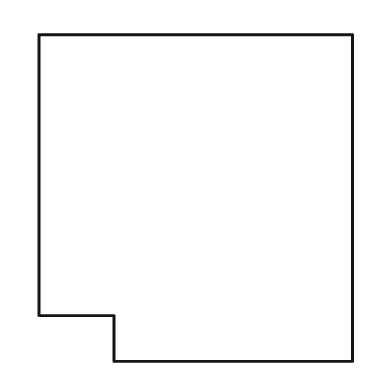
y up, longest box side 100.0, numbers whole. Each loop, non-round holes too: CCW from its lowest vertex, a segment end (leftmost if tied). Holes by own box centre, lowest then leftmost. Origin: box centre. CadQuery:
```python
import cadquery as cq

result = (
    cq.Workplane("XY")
    .moveTo(-25.0, -50.0)
    .lineTo(48.0, -50.0)
    .lineTo(48.0, 50.0)
    .lineTo(-48.0, 50.0)
    .lineTo(-48.0, -36.0)
    .lineTo(-25.0, -36.0)
    .close()
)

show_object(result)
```